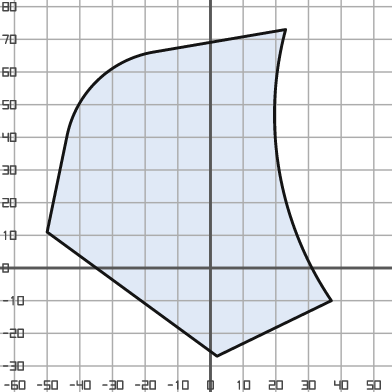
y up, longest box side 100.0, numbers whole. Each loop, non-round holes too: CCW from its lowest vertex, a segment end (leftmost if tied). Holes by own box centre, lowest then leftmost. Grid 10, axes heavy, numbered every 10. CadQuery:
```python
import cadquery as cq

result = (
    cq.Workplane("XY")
    .moveTo(2.0, -27.0)
    .lineTo(37.0, -10.0)
    .threePointArc((21.0, 30.0), (23.0, 73.0))
    .lineTo(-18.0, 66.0)
    .threePointArc((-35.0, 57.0), (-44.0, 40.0))
    .lineTo(-50.0, 11.0)
    .close()
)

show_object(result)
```